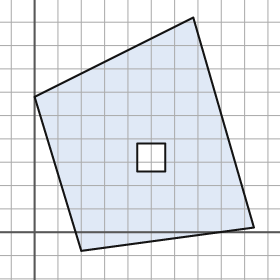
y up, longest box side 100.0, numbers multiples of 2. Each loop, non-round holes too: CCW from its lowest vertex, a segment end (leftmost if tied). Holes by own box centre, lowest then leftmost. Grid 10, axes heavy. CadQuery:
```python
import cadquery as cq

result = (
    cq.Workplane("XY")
    .moveTo(20.0, -8.0)
    .lineTo(94.0, 2.0)
    .lineTo(68.0, 92.0)
    .lineTo(0.0, 58.0)
    .close()
    .moveTo(44.0, 26.0)
    .lineTo(56.0, 26.0)
    .lineTo(56.0, 38.0)
    .lineTo(44.0, 38.0)
    .close()
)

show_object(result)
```